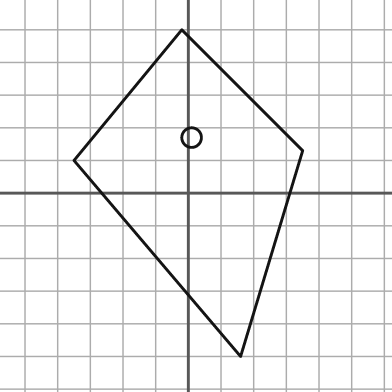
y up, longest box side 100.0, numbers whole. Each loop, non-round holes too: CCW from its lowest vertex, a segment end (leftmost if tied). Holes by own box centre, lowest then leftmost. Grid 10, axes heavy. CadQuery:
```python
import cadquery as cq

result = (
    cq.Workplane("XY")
    .moveTo(16.0, -50.0)
    .lineTo(35.0, 13.0)
    .lineTo(-2.0, 50.0)
    .lineTo(-35.0, 10.0)
    .close()
    .moveTo(1.0, 17.0)
    .circle(3.0)
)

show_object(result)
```